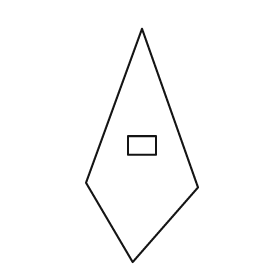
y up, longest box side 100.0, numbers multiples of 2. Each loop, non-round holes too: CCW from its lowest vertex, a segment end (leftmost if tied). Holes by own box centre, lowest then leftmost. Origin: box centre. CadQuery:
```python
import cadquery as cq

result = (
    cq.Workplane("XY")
    .moveTo(-4.0, -50.0)
    .lineTo(24.0, -18.0)
    .lineTo(0.0, 50.0)
    .lineTo(-24.0, -16.0)
    .close()
    .moveTo(-6.0, -4.0)
    .lineTo(6.0, -4.0)
    .lineTo(6.0, 4.0)
    .lineTo(-6.0, 4.0)
    .close()
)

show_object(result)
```